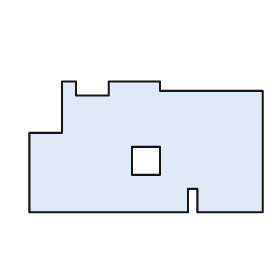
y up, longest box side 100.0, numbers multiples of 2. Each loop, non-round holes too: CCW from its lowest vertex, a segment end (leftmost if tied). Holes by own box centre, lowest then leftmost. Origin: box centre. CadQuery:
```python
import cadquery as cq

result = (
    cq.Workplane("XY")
    .moveTo(-50.0, -28.0)
    .lineTo(18.0, -28.0)
    .lineTo(18.0, -18.0)
    .lineTo(22.0, -18.0)
    .lineTo(22.0, -28.0)
    .lineTo(50.0, -28.0)
    .lineTo(50.0, 24.0)
    .lineTo(6.0, 24.0)
    .lineTo(6.0, 28.0)
    .lineTo(-16.0, 28.0)
    .lineTo(-16.0, 22.0)
    .lineTo(-30.0, 22.0)
    .lineTo(-30.0, 28.0)
    .lineTo(-36.0, 28.0)
    .lineTo(-36.0, 6.0)
    .lineTo(-50.0, 6.0)
    .close()
    .moveTo(-6.0, -12.0)
    .lineTo(6.0, -12.0)
    .lineTo(6.0, 0.0)
    .lineTo(-6.0, 0.0)
    .close()
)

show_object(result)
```